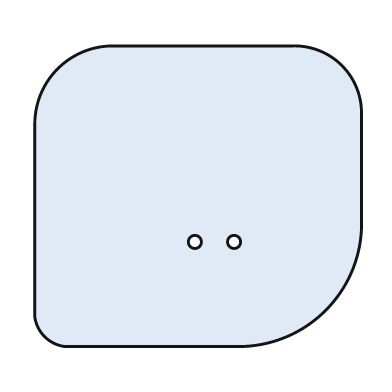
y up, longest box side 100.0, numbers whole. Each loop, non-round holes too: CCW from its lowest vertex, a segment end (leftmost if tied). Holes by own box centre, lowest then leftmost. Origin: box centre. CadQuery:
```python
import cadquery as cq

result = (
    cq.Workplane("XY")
    .moveTo(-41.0, -46.0)
    .lineTo(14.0, -46.0)
    .threePointArc((39.0, -35.0), (50.0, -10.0))
    .lineTo(50.0, 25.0)
    .threePointArc((44.0, 40.0), (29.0, 46.0))
    .lineTo(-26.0, 46.0)
    .threePointArc((-43.0, 39.0), (-50.0, 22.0))
    .lineTo(-50.0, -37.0)
    .threePointArc((-47.0, -43.0), (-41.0, -46.0))
    .close()
    .moveTo(-1.0, -14.0)
    .circle(2.0)
    .moveTo(11.0, -14.0)
    .circle(2.0)
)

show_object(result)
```